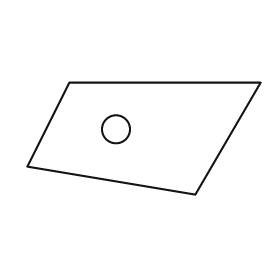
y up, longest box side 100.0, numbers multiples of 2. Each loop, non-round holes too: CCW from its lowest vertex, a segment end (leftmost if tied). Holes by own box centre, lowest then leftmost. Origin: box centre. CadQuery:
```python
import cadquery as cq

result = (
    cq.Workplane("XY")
    .moveTo(22.0, -24.0)
    .lineTo(50.0, 24.0)
    .lineTo(-32.0, 24.0)
    .lineTo(-50.0, -12.0)
    .close()
    .moveTo(-12.0, 4.0)
    .circle(6.0)
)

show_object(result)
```